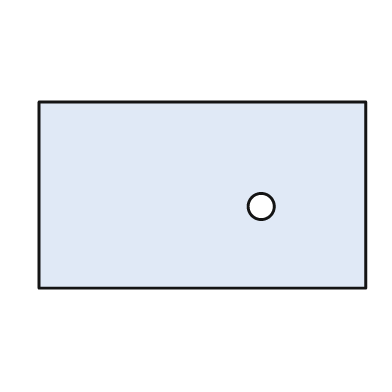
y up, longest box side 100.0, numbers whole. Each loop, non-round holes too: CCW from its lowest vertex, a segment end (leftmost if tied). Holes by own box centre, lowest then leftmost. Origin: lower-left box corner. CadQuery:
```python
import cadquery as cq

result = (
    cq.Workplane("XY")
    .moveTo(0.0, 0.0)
    .lineTo(100.0, 0.0)
    .lineTo(100.0, 57.0)
    .lineTo(0.0, 57.0)
    .close()
    .moveTo(68.0, 25.0)
    .circle(4.0)
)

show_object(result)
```